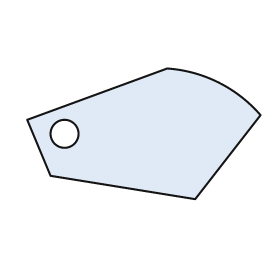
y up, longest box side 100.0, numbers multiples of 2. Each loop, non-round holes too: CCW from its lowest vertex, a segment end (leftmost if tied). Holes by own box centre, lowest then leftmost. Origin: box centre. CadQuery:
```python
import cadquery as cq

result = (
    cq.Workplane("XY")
    .moveTo(22.0, -28.0)
    .lineTo(50.0, 8.0)
    .threePointArc((32.0, 22.0), (10.0, 28.0))
    .lineTo(-50.0, 6.0)
    .lineTo(-40.0, -18.0)
    .close()
    .moveTo(-34.0, 0.0)
    .circle(6.0)
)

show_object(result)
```